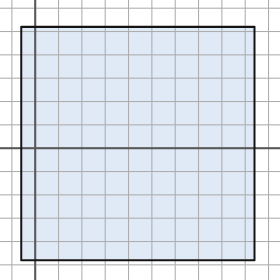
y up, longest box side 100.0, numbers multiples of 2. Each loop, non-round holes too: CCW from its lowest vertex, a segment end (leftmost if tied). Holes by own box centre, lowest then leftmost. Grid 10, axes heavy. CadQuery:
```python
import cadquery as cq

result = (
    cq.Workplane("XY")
    .moveTo(-6.0, -48.0)
    .lineTo(94.0, -48.0)
    .lineTo(94.0, 52.0)
    .lineTo(-6.0, 52.0)
    .close()
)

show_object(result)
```